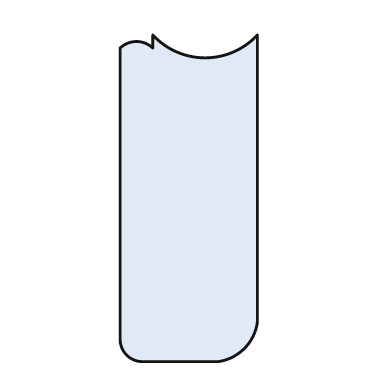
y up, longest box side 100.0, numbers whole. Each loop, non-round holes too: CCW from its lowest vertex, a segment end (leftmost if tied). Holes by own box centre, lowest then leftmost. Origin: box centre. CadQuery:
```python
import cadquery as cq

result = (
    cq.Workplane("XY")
    .moveTo(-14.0, -50.0)
    .lineTo(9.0, -50.0)
    .threePointArc((17.0, -46.0), (21.0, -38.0))
    .lineTo(21.0, 50.0)
    .threePointArc((5.0, 43.0), (-11.0, 50.0))
    .lineTo(-11.0, 46.0)
    .threePointArc((-16.0, 48.0), (-21.0, 46.0))
    .lineTo(-21.0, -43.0)
    .threePointArc((-19.0, -48.0), (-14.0, -50.0))
    .close()
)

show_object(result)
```